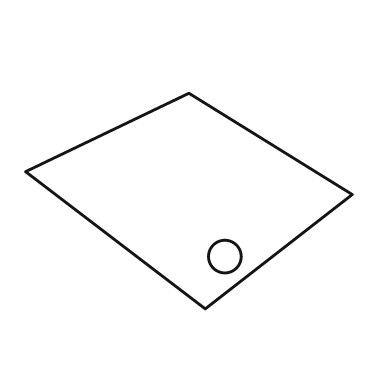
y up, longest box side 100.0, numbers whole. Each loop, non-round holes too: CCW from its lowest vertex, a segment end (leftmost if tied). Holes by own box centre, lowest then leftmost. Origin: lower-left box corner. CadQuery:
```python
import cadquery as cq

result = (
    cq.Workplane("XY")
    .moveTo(55.0, 0.0)
    .lineTo(100.0, 35.0)
    .lineTo(50.0, 66.0)
    .lineTo(0.0, 42.0)
    .close()
    .moveTo(61.0, 16.0)
    .circle(5.0)
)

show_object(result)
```